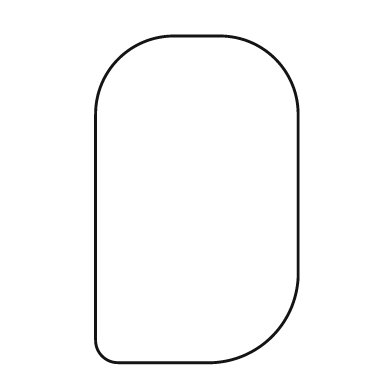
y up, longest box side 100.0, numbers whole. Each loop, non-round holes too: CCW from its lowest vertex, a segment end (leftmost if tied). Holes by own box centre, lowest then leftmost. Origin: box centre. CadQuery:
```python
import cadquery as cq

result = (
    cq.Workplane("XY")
    .moveTo(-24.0, -50.0)
    .lineTo(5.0, -50.0)
    .threePointArc((23.0, -42.0), (31.0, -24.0))
    .lineTo(31.0, 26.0)
    .threePointArc((24.0, 43.0), (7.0, 50.0))
    .lineTo(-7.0, 50.0)
    .threePointArc((-24.0, 43.0), (-31.0, 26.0))
    .lineTo(-31.0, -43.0)
    .threePointArc((-29.0, -48.0), (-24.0, -50.0))
    .close()
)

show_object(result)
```